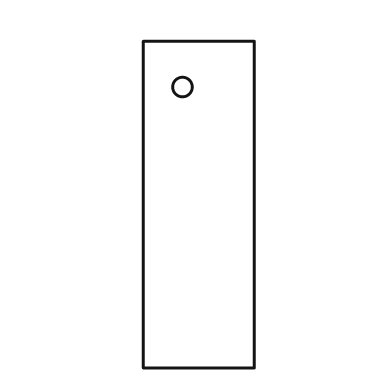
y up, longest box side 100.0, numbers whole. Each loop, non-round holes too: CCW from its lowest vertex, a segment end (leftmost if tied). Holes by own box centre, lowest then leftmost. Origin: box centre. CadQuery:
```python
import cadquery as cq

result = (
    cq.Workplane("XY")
    .moveTo(-17.0, -50.0)
    .lineTo(17.0, -50.0)
    .lineTo(17.0, 50.0)
    .lineTo(-17.0, 50.0)
    .close()
    .moveTo(-5.0, 36.0)
    .circle(3.0)
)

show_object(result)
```